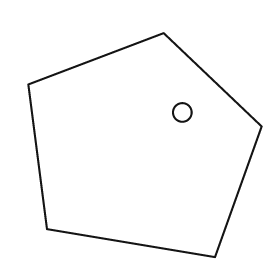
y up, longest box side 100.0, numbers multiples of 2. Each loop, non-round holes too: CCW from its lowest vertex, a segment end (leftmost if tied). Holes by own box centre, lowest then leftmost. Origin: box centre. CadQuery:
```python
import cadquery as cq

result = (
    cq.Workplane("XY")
    .moveTo(30.0, -48.0)
    .lineTo(50.0, 8.0)
    .lineTo(8.0, 48.0)
    .lineTo(-50.0, 26.0)
    .lineTo(-42.0, -36.0)
    .close()
    .moveTo(16.0, 14.0)
    .circle(4.0)
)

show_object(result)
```